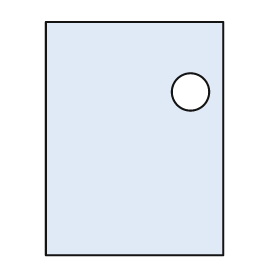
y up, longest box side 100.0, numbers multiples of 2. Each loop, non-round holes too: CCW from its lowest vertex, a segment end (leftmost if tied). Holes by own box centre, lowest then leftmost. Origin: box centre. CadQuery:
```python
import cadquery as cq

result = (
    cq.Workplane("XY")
    .moveTo(-38.0, -50.0)
    .lineTo(38.0, -50.0)
    .lineTo(38.0, 50.0)
    .lineTo(-38.0, 50.0)
    .close()
    .moveTo(24.0, 20.0)
    .circle(8.0)
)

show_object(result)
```